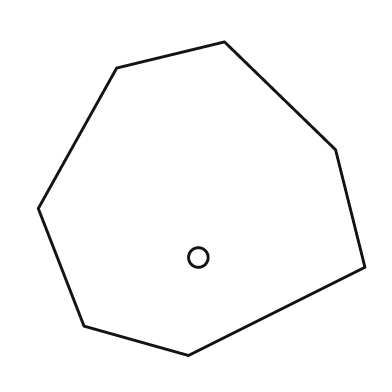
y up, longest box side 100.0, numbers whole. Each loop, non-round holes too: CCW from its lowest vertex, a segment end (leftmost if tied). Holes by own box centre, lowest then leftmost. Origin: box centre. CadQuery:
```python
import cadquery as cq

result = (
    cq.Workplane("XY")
    .moveTo(-4.0, -48.0)
    .lineTo(50.0, -21.0)
    .lineTo(41.0, 15.0)
    .lineTo(7.0, 48.0)
    .lineTo(-26.0, 40.0)
    .lineTo(-50.0, -3.0)
    .lineTo(-36.0, -39.0)
    .close()
    .moveTo(-1.0, -18.0)
    .circle(3.0)
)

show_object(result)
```